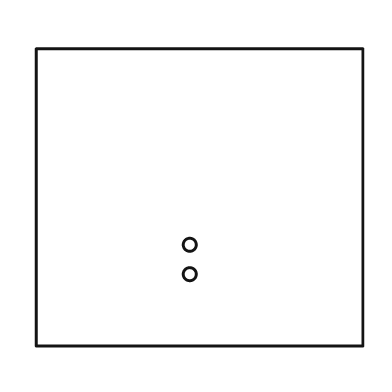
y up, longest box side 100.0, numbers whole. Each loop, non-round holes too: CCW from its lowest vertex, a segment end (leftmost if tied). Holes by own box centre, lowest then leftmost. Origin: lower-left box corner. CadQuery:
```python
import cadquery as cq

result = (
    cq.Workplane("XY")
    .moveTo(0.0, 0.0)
    .lineTo(100.0, 0.0)
    .lineTo(100.0, 91.0)
    .lineTo(0.0, 91.0)
    .close()
    .moveTo(47.0, 22.0)
    .circle(2.0)
    .moveTo(47.0, 31.0)
    .circle(2.0)
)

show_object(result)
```